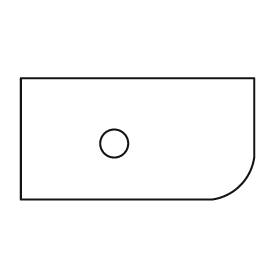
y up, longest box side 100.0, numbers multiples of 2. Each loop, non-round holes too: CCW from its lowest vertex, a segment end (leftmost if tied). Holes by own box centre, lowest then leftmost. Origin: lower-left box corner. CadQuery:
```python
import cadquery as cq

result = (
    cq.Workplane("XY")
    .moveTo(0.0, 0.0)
    .lineTo(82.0, 0.0)
    .threePointArc((94.0, 6.0), (100.0, 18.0))
    .lineTo(100.0, 52.0)
    .lineTo(0.0, 52.0)
    .close()
    .moveTo(40.0, 24.0)
    .circle(6.0)
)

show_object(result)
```